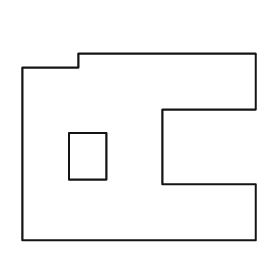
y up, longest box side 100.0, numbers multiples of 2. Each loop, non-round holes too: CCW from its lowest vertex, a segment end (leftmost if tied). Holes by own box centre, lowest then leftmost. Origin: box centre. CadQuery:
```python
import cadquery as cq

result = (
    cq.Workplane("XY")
    .moveTo(-50.0, -40.0)
    .lineTo(50.0, -40.0)
    .lineTo(50.0, -16.0)
    .lineTo(10.0, -16.0)
    .lineTo(10.0, 16.0)
    .lineTo(50.0, 16.0)
    .lineTo(50.0, 40.0)
    .lineTo(-26.0, 40.0)
    .lineTo(-26.0, 34.0)
    .lineTo(-50.0, 34.0)
    .close()
    .moveTo(-30.0, -14.0)
    .lineTo(-14.0, -14.0)
    .lineTo(-14.0, 6.0)
    .lineTo(-30.0, 6.0)
    .close()
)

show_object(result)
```